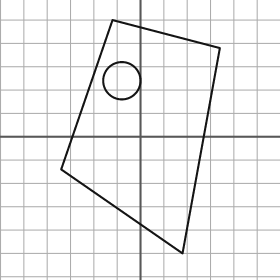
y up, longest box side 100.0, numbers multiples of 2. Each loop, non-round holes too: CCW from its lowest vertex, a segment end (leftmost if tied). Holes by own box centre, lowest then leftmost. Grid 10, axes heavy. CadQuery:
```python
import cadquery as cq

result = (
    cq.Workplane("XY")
    .moveTo(18.0, -50.0)
    .lineTo(34.0, 38.0)
    .lineTo(-12.0, 50.0)
    .lineTo(-34.0, -14.0)
    .close()
    .moveTo(-8.0, 24.0)
    .circle(8.0)
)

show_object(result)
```